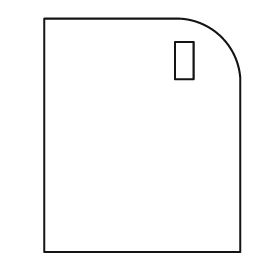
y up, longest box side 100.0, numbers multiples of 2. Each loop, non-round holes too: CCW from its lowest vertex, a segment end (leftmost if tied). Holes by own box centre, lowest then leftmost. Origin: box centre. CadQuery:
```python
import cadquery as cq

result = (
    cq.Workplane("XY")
    .moveTo(-42.0, -50.0)
    .lineTo(42.0, -50.0)
    .lineTo(42.0, 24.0)
    .threePointArc((34.0, 42.0), (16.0, 50.0))
    .lineTo(-42.0, 50.0)
    .close()
    .moveTo(14.0, 24.0)
    .lineTo(22.0, 24.0)
    .lineTo(22.0, 40.0)
    .lineTo(14.0, 40.0)
    .close()
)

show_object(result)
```